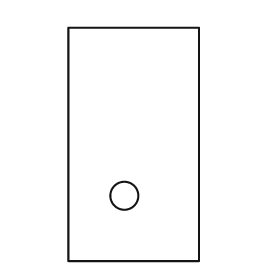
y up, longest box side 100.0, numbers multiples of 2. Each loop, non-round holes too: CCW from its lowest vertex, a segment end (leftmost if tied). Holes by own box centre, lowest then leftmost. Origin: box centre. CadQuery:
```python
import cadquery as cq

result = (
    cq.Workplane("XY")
    .moveTo(-28.0, -50.0)
    .lineTo(28.0, -50.0)
    .lineTo(28.0, 50.0)
    .lineTo(-28.0, 50.0)
    .close()
    .moveTo(-4.0, -22.0)
    .circle(6.0)
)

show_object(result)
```